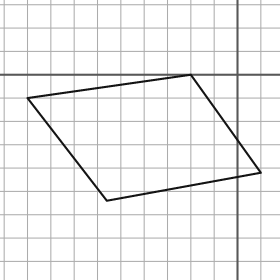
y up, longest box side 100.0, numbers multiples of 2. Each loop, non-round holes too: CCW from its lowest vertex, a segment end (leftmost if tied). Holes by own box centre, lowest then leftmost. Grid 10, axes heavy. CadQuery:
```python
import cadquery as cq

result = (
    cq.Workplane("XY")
    .moveTo(-56.0, -54.0)
    .lineTo(10.0, -42.0)
    .lineTo(-20.0, 0.0)
    .lineTo(-90.0, -10.0)
    .close()
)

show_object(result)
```